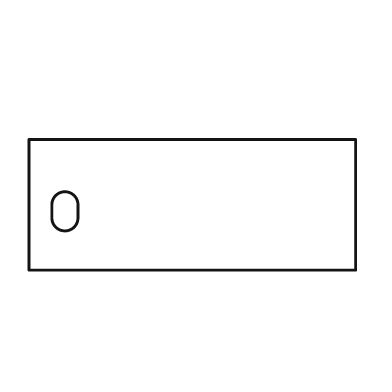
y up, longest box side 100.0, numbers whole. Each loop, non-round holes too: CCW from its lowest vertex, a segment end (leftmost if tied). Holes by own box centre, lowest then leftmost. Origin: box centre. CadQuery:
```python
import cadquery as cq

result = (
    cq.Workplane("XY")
    .moveTo(-50.0, -20.0)
    .lineTo(50.0, -20.0)
    .lineTo(50.0, 20.0)
    .lineTo(-50.0, 20.0)
    .close()
    .moveTo(-43.0, -4.0)
    .threePointArc((-39.0, -8.0), (-35.0, -4.0))
    .lineTo(-35.0, 0.0)
    .threePointArc((-39.0, 4.0), (-43.0, 0.0))
    .close()
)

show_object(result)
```